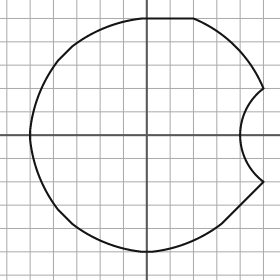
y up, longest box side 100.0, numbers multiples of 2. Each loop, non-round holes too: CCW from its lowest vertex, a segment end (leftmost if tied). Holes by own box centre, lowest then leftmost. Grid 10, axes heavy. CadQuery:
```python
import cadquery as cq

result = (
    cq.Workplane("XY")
    .moveTo(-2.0, -50.0)
    .lineTo(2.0, -50.0)
    .threePointArc((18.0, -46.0), (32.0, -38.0))
    .lineTo(50.0, -20.0)
    .threePointArc((40.0, 0.0), (50.0, 20.0))
    .threePointArc((38.0, 38.0), (20.0, 50.0))
    .lineTo(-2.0, 50.0)
    .threePointArc((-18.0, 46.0), (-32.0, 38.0))
    .lineTo(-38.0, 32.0)
    .threePointArc((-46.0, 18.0), (-50.0, 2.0))
    .lineTo(-50.0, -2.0)
    .threePointArc((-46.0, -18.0), (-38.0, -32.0))
    .lineTo(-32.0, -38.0)
    .threePointArc((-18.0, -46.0), (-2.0, -50.0))
    .close()
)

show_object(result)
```